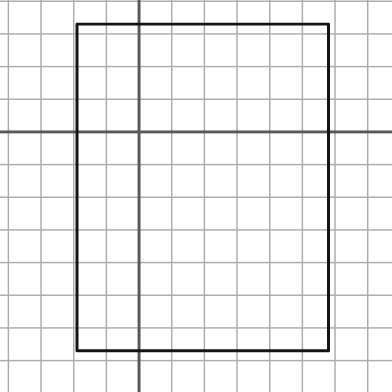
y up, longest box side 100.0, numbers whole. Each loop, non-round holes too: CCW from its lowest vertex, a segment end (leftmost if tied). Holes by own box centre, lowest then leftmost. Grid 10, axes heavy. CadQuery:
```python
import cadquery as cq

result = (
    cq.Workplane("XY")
    .moveTo(-19.0, -67.0)
    .lineTo(58.0, -67.0)
    .lineTo(58.0, 33.0)
    .lineTo(-19.0, 33.0)
    .close()
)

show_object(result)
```